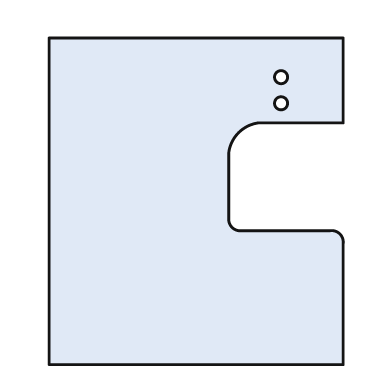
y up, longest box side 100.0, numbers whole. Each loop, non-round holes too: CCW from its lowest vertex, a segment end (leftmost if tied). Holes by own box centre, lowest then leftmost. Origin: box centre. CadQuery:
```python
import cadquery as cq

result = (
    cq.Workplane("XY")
    .moveTo(-45.0, -50.0)
    .lineTo(45.0, -50.0)
    .lineTo(45.0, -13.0)
    .threePointArc((44.0, -10.0), (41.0, -9.0))
    .lineTo(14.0, -9.0)
    .threePointArc((11.0, -8.0), (10.0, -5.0))
    .lineTo(10.0, 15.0)
    .threePointArc((13.0, 21.0), (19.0, 24.0))
    .lineTo(45.0, 24.0)
    .lineTo(45.0, 50.0)
    .lineTo(-45.0, 50.0)
    .close()
    .moveTo(26.0, 30.0)
    .circle(2.0)
    .moveTo(26.0, 38.0)
    .circle(2.0)
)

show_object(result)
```